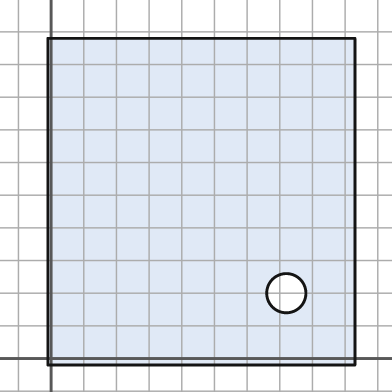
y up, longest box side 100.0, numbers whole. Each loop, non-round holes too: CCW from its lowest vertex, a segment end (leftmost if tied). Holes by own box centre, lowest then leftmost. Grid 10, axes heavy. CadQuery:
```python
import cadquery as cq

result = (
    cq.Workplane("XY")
    .moveTo(-1.0, -2.0)
    .lineTo(93.0, -2.0)
    .lineTo(93.0, 98.0)
    .lineTo(-1.0, 98.0)
    .close()
    .moveTo(72.0, 20.0)
    .circle(6.0)
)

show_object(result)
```